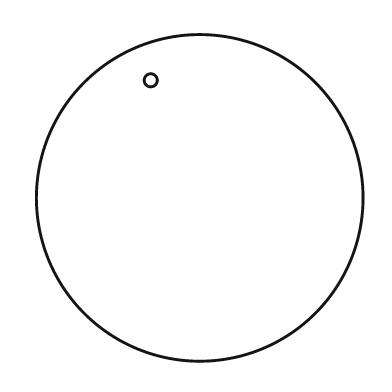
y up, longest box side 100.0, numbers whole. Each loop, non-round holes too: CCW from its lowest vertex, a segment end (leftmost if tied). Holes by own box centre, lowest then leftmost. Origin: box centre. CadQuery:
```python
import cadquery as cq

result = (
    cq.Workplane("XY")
    .moveTo(0.0, 0.0)
    .circle(50.0)
    .moveTo(-15.0, 36.0)
    .circle(2.0)
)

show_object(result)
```